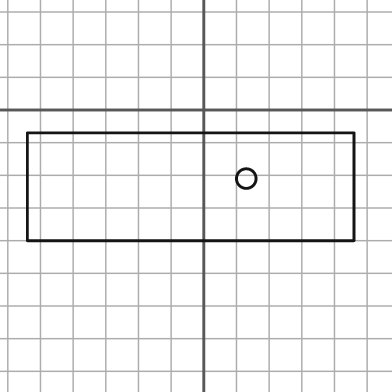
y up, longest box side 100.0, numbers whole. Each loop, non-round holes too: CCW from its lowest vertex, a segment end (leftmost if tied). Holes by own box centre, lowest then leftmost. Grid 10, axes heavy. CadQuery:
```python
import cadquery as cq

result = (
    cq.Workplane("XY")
    .moveTo(-54.0, -40.0)
    .lineTo(46.0, -40.0)
    .lineTo(46.0, -7.0)
    .lineTo(-54.0, -7.0)
    .close()
    .moveTo(13.0, -21.0)
    .circle(3.0)
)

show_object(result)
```